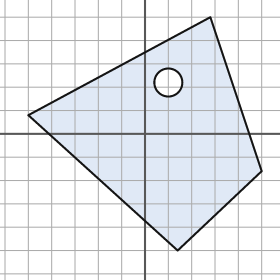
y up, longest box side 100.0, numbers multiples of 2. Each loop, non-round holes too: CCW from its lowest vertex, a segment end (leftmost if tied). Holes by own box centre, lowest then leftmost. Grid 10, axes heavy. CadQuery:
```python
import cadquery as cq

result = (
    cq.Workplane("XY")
    .moveTo(14.0, -50.0)
    .lineTo(50.0, -16.0)
    .lineTo(28.0, 50.0)
    .lineTo(-50.0, 8.0)
    .close()
    .moveTo(10.0, 22.0)
    .circle(6.0)
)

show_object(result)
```